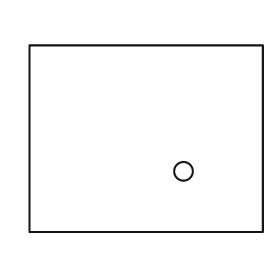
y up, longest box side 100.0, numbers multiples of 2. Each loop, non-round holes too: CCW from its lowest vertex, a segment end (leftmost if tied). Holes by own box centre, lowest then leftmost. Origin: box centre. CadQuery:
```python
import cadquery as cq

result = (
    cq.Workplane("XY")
    .moveTo(-50.0, -40.0)
    .lineTo(50.0, -40.0)
    .lineTo(50.0, 40.0)
    .lineTo(-50.0, 40.0)
    .close()
    .moveTo(16.0, -14.0)
    .circle(4.0)
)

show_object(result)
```